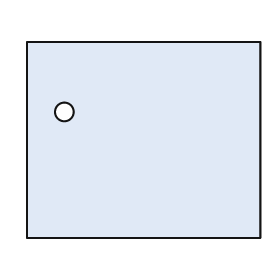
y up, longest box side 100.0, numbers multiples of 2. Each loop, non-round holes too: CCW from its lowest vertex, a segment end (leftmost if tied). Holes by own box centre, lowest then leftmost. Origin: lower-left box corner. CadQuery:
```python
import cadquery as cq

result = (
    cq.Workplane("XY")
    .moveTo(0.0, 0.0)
    .lineTo(100.0, 0.0)
    .lineTo(100.0, 84.0)
    .lineTo(0.0, 84.0)
    .close()
    .moveTo(16.0, 54.0)
    .circle(4.0)
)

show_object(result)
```